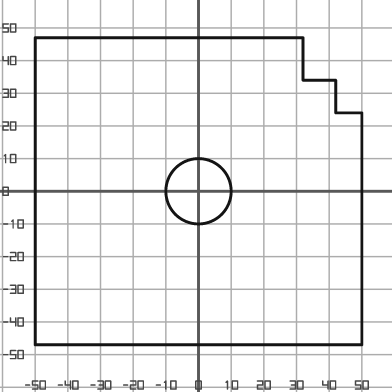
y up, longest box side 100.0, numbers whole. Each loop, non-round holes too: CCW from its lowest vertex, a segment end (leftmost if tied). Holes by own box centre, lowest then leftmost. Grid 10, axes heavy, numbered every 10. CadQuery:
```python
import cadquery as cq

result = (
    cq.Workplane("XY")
    .moveTo(-50.0, -47.0)
    .lineTo(50.0, -47.0)
    .lineTo(50.0, 24.0)
    .lineTo(42.0, 24.0)
    .lineTo(42.0, 34.0)
    .lineTo(32.0, 34.0)
    .lineTo(32.0, 47.0)
    .lineTo(-50.0, 47.0)
    .close()
    .moveTo(0.0, 0.0)
    .circle(10.0)
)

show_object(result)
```